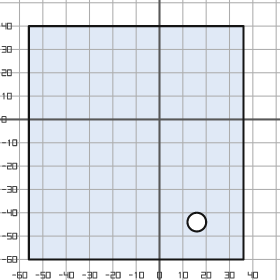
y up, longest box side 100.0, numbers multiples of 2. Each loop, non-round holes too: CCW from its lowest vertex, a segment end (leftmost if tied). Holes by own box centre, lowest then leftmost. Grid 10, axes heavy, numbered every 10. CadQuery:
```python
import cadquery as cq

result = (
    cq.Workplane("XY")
    .moveTo(-56.0, -60.0)
    .lineTo(36.0, -60.0)
    .lineTo(36.0, 40.0)
    .lineTo(-56.0, 40.0)
    .close()
    .moveTo(16.0, -44.0)
    .circle(4.0)
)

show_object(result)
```